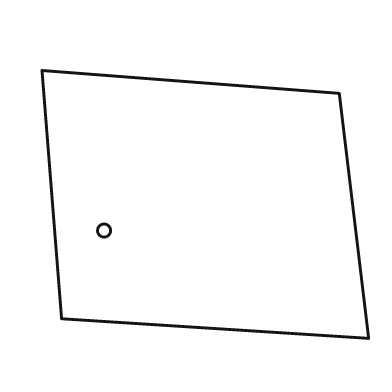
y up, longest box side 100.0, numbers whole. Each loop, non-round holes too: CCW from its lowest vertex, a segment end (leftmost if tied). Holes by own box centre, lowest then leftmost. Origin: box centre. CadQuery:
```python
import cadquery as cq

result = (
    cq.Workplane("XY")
    .moveTo(50.0, -41.0)
    .lineTo(41.0, 34.0)
    .lineTo(-50.0, 41.0)
    .lineTo(-44.0, -35.0)
    .close()
    .moveTo(-31.0, -8.0)
    .circle(2.0)
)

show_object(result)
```